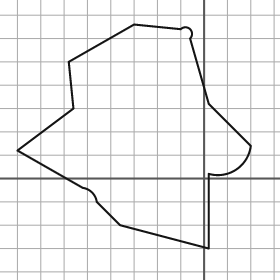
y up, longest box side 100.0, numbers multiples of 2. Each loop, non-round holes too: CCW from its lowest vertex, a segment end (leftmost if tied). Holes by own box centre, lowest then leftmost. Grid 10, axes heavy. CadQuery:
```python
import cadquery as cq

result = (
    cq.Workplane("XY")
    .moveTo(2.0, -30.0)
    .lineTo(2.0, 2.0)
    .threePointArc((14.0, 4.0), (20.0, 14.0))
    .lineTo(2.0, 32.0)
    .lineTo(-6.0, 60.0)
    .threePointArc((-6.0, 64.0), (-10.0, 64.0))
    .lineTo(-30.0, 66.0)
    .lineTo(-58.0, 50.0)
    .lineTo(-56.0, 30.0)
    .lineTo(-80.0, 12.0)
    .lineTo(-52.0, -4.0)
    .threePointArc((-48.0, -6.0), (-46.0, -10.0))
    .lineTo(-36.0, -20.0)
    .close()
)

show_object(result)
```